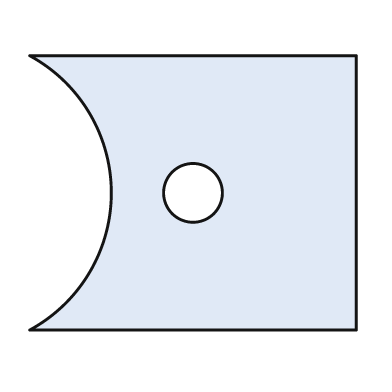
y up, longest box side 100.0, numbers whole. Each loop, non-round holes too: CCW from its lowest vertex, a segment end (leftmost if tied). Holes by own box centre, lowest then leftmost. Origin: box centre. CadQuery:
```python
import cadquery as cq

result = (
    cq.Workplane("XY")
    .moveTo(-50.0, -42.0)
    .lineTo(50.0, -42.0)
    .lineTo(50.0, 42.0)
    .lineTo(-50.0, 42.0)
    .threePointArc((-25.0, 0.0), (-50.0, -42.0))
    .close()
    .moveTo(0.0, 0.0)
    .circle(9.0)
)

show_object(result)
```